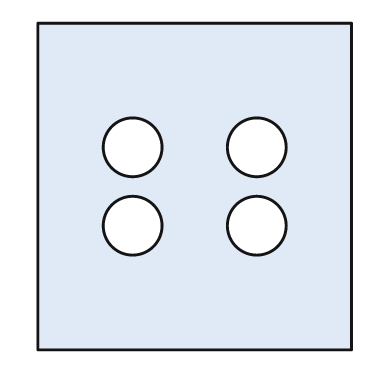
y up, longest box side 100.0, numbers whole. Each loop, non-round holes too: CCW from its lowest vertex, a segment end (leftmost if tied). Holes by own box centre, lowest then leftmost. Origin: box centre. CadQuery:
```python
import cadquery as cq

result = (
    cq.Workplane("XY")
    .moveTo(-48.0, -50.0)
    .lineTo(48.0, -50.0)
    .lineTo(48.0, 50.0)
    .lineTo(-48.0, 50.0)
    .close()
    .moveTo(-19.0, -12.0)
    .circle(9.0)
    .moveTo(19.0, -12.0)
    .circle(9.0)
    .moveTo(-19.0, 12.0)
    .circle(9.0)
    .moveTo(19.0, 12.0)
    .circle(9.0)
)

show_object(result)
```